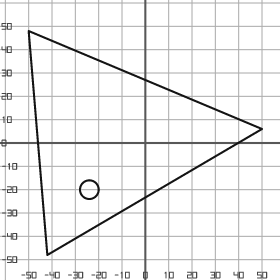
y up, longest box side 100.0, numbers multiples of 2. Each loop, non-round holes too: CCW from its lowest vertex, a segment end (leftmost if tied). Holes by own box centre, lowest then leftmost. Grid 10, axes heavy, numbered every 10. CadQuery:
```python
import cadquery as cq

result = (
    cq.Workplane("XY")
    .moveTo(-42.0, -48.0)
    .lineTo(50.0, 6.0)
    .lineTo(-50.0, 48.0)
    .close()
    .moveTo(-24.0, -20.0)
    .circle(4.0)
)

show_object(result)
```